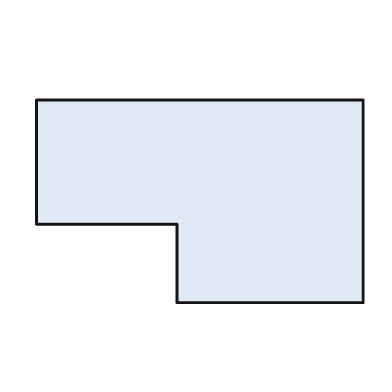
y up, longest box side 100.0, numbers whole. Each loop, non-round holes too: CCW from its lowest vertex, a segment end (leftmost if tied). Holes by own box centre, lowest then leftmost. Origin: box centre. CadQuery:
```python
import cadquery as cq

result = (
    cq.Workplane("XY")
    .moveTo(-7.0, -31.0)
    .lineTo(50.0, -31.0)
    .lineTo(50.0, 31.0)
    .lineTo(-50.0, 31.0)
    .lineTo(-50.0, -7.0)
    .lineTo(-7.0, -7.0)
    .close()
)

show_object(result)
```